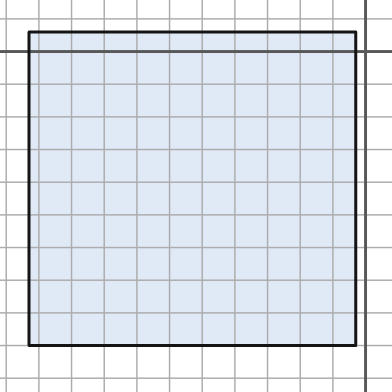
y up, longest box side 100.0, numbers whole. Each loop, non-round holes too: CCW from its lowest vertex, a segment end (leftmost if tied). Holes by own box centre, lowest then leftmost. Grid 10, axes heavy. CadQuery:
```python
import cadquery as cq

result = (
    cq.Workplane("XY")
    .moveTo(-103.0, -90.0)
    .lineTo(-3.0, -90.0)
    .lineTo(-3.0, 6.0)
    .lineTo(-103.0, 6.0)
    .close()
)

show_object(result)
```